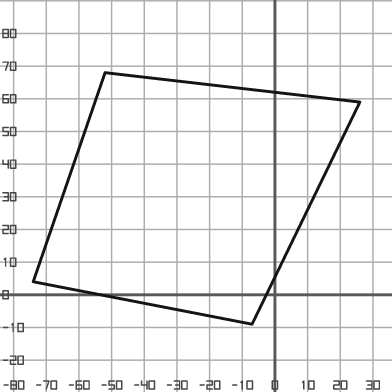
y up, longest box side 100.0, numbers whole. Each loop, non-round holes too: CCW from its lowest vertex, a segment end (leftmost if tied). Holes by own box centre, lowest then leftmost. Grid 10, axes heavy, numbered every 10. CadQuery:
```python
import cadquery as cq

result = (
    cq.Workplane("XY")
    .moveTo(-7.0, -9.0)
    .lineTo(26.0, 59.0)
    .lineTo(-52.0, 68.0)
    .lineTo(-74.0, 4.0)
    .close()
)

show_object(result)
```